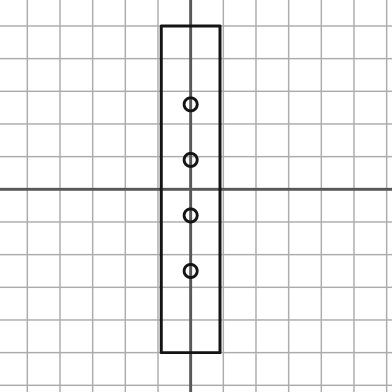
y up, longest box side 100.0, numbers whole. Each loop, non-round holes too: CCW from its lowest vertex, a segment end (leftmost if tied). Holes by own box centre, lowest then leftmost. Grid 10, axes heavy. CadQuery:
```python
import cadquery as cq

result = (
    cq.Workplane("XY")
    .moveTo(-9.0, -50.0)
    .lineTo(9.0, -50.0)
    .lineTo(9.0, 50.0)
    .lineTo(-9.0, 50.0)
    .close()
    .moveTo(0.0, -25.0)
    .circle(2.0)
    .moveTo(0.0, -8.0)
    .circle(2.0)
    .moveTo(0.0, 9.0)
    .circle(2.0)
    .moveTo(0.0, 26.0)
    .circle(2.0)
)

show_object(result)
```